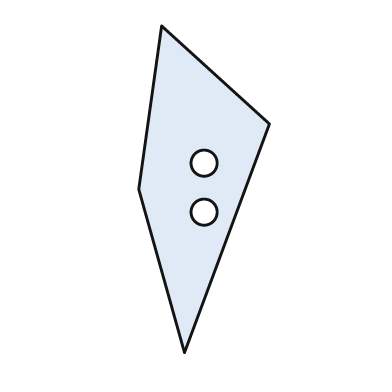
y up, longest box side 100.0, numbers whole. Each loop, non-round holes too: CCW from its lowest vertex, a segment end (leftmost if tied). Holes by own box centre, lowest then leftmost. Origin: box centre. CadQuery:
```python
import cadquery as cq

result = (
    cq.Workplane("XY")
    .moveTo(-6.0, -50.0)
    .lineTo(20.0, 20.0)
    .lineTo(-13.0, 50.0)
    .lineTo(-20.0, 0.0)
    .close()
    .moveTo(0.0, -7.0)
    .circle(4.0)
    .moveTo(0.0, 8.0)
    .circle(4.0)
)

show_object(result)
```